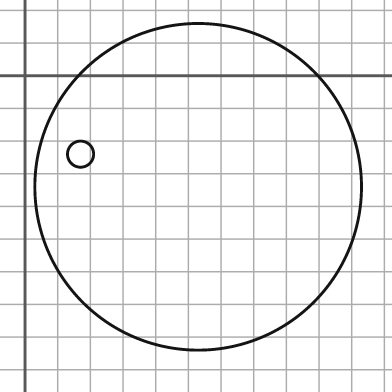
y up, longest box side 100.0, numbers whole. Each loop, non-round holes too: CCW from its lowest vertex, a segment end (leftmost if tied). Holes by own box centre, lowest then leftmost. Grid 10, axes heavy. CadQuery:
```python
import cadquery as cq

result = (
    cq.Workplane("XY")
    .moveTo(53.0, -34.0)
    .circle(50.0)
    .moveTo(17.0, -24.0)
    .circle(4.0)
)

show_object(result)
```